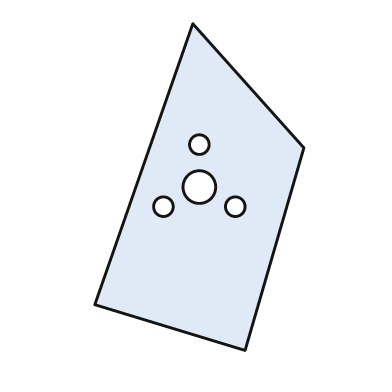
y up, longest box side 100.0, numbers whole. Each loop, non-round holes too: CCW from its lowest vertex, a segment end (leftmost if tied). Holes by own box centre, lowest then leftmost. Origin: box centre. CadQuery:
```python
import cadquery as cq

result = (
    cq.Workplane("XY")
    .moveTo(14.0, -50.0)
    .lineTo(32.0, 12.0)
    .lineTo(-2.0, 50.0)
    .lineTo(-32.0, -36.0)
    .close()
    .moveTo(-11.0, -6.0)
    .circle(3.0)
    .moveTo(11.0, -6.0)
    .circle(3.0)
    .moveTo(0.0, 0.0)
    .circle(5.0)
    .moveTo(0.0, 13.0)
    .circle(3.0)
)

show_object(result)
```